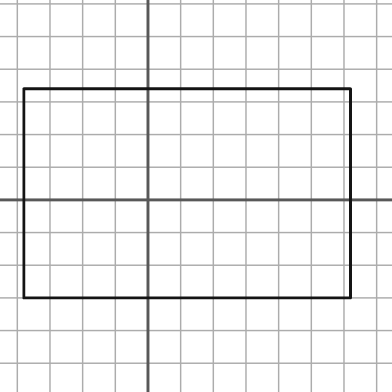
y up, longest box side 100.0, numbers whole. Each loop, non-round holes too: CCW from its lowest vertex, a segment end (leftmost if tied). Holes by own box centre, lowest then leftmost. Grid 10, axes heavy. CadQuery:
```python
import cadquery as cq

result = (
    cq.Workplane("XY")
    .moveTo(-38.0, -30.0)
    .lineTo(62.0, -30.0)
    .lineTo(62.0, 34.0)
    .lineTo(-38.0, 34.0)
    .close()
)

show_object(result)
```